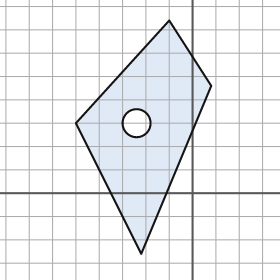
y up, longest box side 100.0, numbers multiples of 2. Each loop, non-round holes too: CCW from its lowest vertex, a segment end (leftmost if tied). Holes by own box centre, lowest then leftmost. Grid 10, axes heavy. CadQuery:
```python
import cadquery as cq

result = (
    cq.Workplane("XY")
    .moveTo(-22.0, -26.0)
    .lineTo(8.0, 46.0)
    .lineTo(-10.0, 74.0)
    .lineTo(-50.0, 30.0)
    .close()
    .moveTo(-24.0, 30.0)
    .circle(6.0)
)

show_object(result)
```